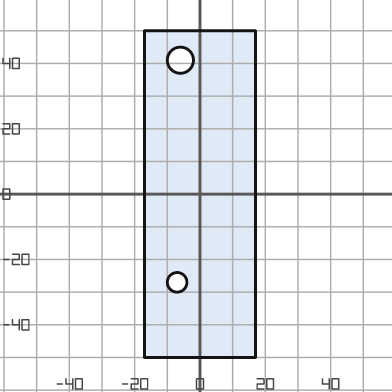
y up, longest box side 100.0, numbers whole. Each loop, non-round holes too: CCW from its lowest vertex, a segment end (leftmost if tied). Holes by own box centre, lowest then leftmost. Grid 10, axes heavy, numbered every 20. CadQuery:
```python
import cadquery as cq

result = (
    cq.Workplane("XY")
    .moveTo(-17.0, -50.0)
    .lineTo(17.0, -50.0)
    .lineTo(17.0, 50.0)
    .lineTo(-17.0, 50.0)
    .close()
    .moveTo(-7.0, -27.0)
    .circle(3.0)
    .moveTo(-6.0, 41.0)
    .circle(4.0)
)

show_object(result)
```